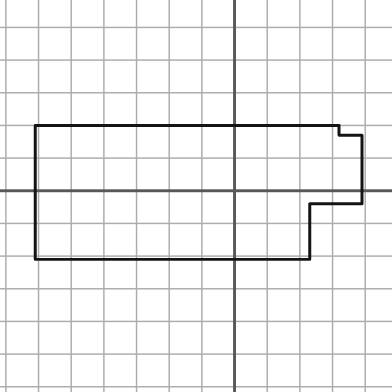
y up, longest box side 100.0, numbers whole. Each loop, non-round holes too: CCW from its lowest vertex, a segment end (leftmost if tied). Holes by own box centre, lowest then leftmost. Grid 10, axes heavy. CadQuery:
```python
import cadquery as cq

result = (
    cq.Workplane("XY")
    .moveTo(-61.0, -21.0)
    .lineTo(23.0, -21.0)
    .lineTo(23.0, -4.0)
    .lineTo(39.0, -4.0)
    .lineTo(39.0, 17.0)
    .lineTo(32.0, 17.0)
    .lineTo(32.0, 20.0)
    .lineTo(-61.0, 20.0)
    .close()
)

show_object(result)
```